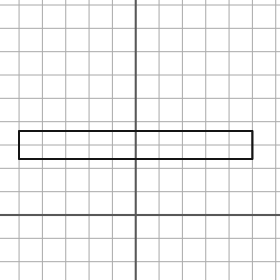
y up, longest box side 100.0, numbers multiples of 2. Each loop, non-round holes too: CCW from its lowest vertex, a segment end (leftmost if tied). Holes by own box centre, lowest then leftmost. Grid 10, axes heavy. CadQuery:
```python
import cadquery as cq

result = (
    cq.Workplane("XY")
    .moveTo(-50.0, 24.0)
    .lineTo(50.0, 24.0)
    .lineTo(50.0, 36.0)
    .lineTo(-50.0, 36.0)
    .close()
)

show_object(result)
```